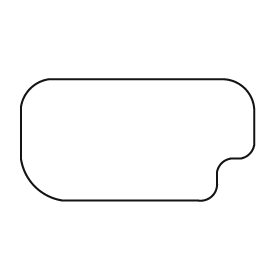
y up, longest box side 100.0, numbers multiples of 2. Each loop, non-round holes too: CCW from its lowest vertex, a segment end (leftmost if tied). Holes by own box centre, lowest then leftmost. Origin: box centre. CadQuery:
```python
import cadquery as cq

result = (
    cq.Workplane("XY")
    .moveTo(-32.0, -26.0)
    .lineTo(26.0, -26.0)
    .threePointArc((32.0, -24.0), (34.0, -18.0))
    .lineTo(34.0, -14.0)
    .threePointArc((36.0, -10.0), (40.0, -8.0))
    .lineTo(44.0, -8.0)
    .threePointArc((48.0, -6.0), (50.0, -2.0))
    .lineTo(50.0, 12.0)
    .threePointArc((46.0, 22.0), (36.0, 26.0))
    .lineTo(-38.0, 26.0)
    .threePointArc((-46.0, 22.0), (-50.0, 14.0))
    .lineTo(-50.0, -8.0)
    .threePointArc((-44.0, -20.0), (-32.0, -26.0))
    .close()
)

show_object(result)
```